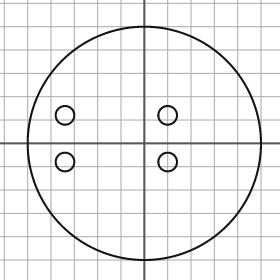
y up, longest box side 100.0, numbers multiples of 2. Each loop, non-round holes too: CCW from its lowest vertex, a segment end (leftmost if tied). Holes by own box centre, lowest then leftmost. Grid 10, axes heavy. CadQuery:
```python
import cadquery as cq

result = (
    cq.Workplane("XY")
    .moveTo(0.0, 0.0)
    .circle(50.0)
    .moveTo(-34.0, -8.0)
    .circle(4.0)
    .moveTo(10.0, -8.0)
    .circle(4.0)
    .moveTo(-34.0, 12.0)
    .circle(4.0)
    .moveTo(10.0, 12.0)
    .circle(4.0)
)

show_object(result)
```